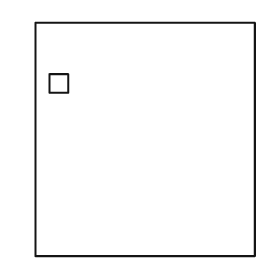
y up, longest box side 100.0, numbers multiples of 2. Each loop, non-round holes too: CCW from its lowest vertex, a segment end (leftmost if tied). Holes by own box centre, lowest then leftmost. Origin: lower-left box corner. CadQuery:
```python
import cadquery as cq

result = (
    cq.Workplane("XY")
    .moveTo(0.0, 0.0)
    .lineTo(94.0, 0.0)
    .lineTo(94.0, 100.0)
    .lineTo(0.0, 100.0)
    .close()
    .moveTo(6.0, 70.0)
    .lineTo(14.0, 70.0)
    .lineTo(14.0, 78.0)
    .lineTo(6.0, 78.0)
    .close()
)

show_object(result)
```